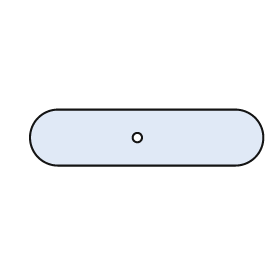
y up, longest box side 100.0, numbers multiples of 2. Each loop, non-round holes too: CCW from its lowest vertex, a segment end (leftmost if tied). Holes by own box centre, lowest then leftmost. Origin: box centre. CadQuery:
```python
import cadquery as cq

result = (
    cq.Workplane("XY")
    .moveTo(-38.0, -12.0)
    .lineTo(38.0, -12.0)
    .threePointArc((50.0, 0.0), (38.0, 12.0))
    .lineTo(-38.0, 12.0)
    .threePointArc((-50.0, 0.0), (-38.0, -12.0))
    .close()
    .moveTo(-4.0, 0.0)
    .circle(2.0)
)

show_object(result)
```